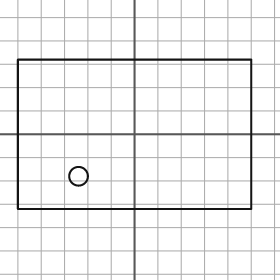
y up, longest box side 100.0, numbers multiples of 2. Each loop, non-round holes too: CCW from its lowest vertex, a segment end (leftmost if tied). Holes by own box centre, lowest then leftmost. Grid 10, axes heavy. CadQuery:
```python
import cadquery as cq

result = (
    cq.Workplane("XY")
    .moveTo(-50.0, -32.0)
    .lineTo(50.0, -32.0)
    .lineTo(50.0, 32.0)
    .lineTo(-50.0, 32.0)
    .close()
    .moveTo(-24.0, -18.0)
    .circle(4.0)
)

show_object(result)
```